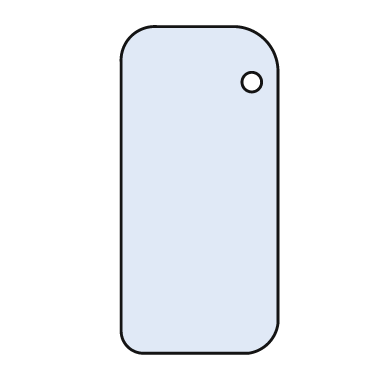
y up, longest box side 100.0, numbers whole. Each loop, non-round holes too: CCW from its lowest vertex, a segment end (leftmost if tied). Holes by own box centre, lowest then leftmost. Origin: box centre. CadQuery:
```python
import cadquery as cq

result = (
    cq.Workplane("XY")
    .moveTo(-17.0, -50.0)
    .lineTo(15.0, -50.0)
    .threePointArc((21.0, -47.0), (24.0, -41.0))
    .lineTo(24.0, 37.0)
    .threePointArc((20.0, 46.0), (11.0, 50.0))
    .lineTo(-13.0, 50.0)
    .threePointArc((-21.0, 47.0), (-24.0, 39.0))
    .lineTo(-24.0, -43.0)
    .threePointArc((-22.0, -48.0), (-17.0, -50.0))
    .close()
    .moveTo(16.0, 33.0)
    .circle(3.0)
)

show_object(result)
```